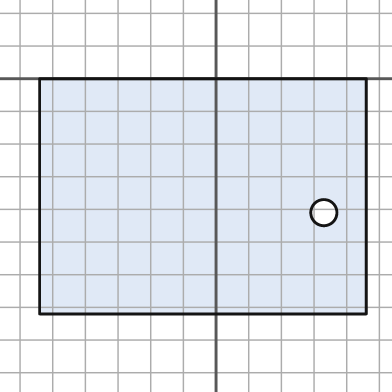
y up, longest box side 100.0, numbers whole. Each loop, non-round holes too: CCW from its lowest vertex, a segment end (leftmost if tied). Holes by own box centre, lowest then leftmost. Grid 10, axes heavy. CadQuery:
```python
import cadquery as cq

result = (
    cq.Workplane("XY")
    .moveTo(-54.0, -72.0)
    .lineTo(46.0, -72.0)
    .lineTo(46.0, 0.0)
    .lineTo(-54.0, 0.0)
    .close()
    .moveTo(33.0, -41.0)
    .circle(4.0)
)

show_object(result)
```